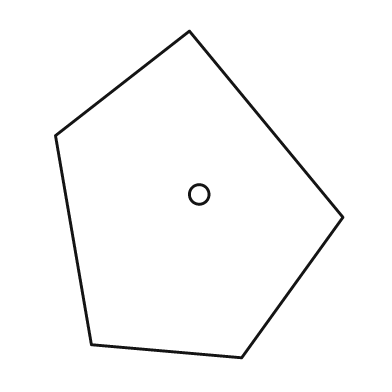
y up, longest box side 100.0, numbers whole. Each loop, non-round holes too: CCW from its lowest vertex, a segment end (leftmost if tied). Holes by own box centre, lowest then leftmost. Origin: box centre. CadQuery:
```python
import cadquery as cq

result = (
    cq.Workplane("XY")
    .moveTo(13.0, -50.0)
    .lineTo(44.0, -7.0)
    .lineTo(-3.0, 50.0)
    .lineTo(-44.0, 18.0)
    .lineTo(-33.0, -46.0)
    .close()
    .moveTo(0.0, 0.0)
    .circle(3.0)
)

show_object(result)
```